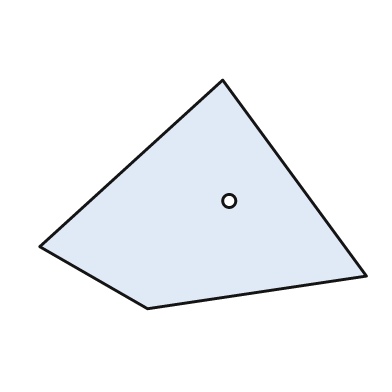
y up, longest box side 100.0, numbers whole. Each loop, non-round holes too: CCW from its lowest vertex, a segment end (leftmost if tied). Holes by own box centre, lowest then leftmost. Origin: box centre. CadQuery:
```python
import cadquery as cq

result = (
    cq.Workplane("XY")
    .moveTo(-17.0, -35.0)
    .lineTo(50.0, -25.0)
    .lineTo(6.0, 35.0)
    .lineTo(-50.0, -16.0)
    .close()
    .moveTo(8.0, -2.0)
    .circle(2.0)
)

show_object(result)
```